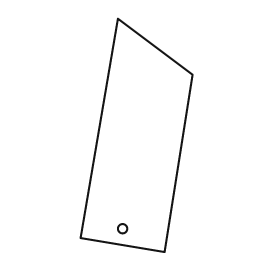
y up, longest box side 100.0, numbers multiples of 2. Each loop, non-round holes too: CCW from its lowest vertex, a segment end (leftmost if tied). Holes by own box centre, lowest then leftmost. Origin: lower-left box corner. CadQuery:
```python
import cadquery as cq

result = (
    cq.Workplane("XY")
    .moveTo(36.0, 0.0)
    .lineTo(48.0, 76.0)
    .lineTo(16.0, 100.0)
    .lineTo(0.0, 6.0)
    .close()
    .moveTo(18.0, 10.0)
    .circle(2.0)
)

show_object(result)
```